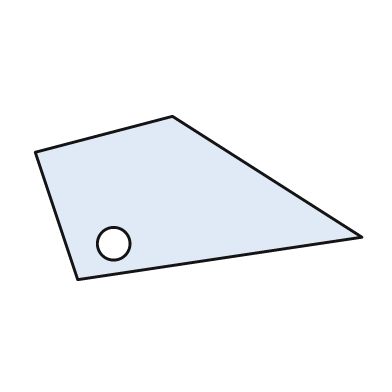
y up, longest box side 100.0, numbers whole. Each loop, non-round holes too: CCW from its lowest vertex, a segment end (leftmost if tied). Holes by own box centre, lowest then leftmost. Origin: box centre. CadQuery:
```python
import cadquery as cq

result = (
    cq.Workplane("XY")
    .moveTo(-37.0, -25.0)
    .lineTo(50.0, -12.0)
    .lineTo(-8.0, 25.0)
    .lineTo(-50.0, 14.0)
    .close()
    .moveTo(-26.0, -14.0)
    .circle(5.0)
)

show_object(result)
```